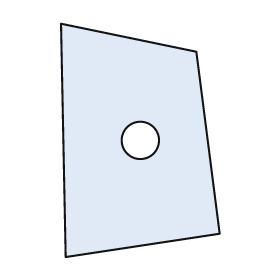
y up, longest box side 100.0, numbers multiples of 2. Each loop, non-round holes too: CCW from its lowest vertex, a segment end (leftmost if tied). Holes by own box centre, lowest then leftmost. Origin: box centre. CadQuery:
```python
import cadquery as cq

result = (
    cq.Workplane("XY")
    .moveTo(-32.0, -50.0)
    .lineTo(34.0, -40.0)
    .lineTo(24.0, 38.0)
    .lineTo(-34.0, 50.0)
    .close()
    .moveTo(0.0, 0.0)
    .circle(8.0)
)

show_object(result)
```